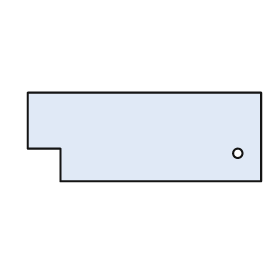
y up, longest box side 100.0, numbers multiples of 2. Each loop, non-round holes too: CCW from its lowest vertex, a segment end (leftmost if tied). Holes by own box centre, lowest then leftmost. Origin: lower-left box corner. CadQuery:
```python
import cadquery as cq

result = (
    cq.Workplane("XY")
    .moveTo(14.0, 0.0)
    .lineTo(100.0, 0.0)
    .lineTo(100.0, 38.0)
    .lineTo(0.0, 38.0)
    .lineTo(0.0, 14.0)
    .lineTo(14.0, 14.0)
    .close()
    .moveTo(90.0, 12.0)
    .circle(2.0)
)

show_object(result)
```